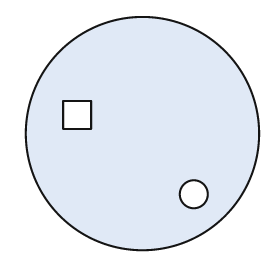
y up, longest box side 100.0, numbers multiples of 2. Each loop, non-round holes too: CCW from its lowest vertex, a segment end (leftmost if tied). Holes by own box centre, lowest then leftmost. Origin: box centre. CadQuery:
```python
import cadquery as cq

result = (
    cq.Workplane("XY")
    .moveTo(0.0, 0.0)
    .circle(50.0)
    .moveTo(22.0, -26.0)
    .circle(6.0)
    .moveTo(-34.0, 2.0)
    .lineTo(-22.0, 2.0)
    .lineTo(-22.0, 14.0)
    .lineTo(-34.0, 14.0)
    .close()
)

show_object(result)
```